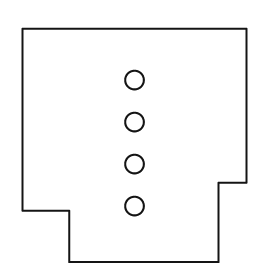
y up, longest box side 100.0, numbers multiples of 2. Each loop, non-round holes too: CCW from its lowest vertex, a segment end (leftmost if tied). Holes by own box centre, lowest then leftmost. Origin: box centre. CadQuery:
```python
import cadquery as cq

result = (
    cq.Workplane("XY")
    .moveTo(-28.0, -50.0)
    .lineTo(36.0, -50.0)
    .lineTo(36.0, -16.0)
    .lineTo(48.0, -16.0)
    .lineTo(48.0, 50.0)
    .lineTo(-48.0, 50.0)
    .lineTo(-48.0, -28.0)
    .lineTo(-28.0, -28.0)
    .close()
    .moveTo(0.0, -26.0)
    .circle(4.0)
    .moveTo(0.0, -8.0)
    .circle(4.0)
    .moveTo(0.0, 10.0)
    .circle(4.0)
    .moveTo(0.0, 28.0)
    .circle(4.0)
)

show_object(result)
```